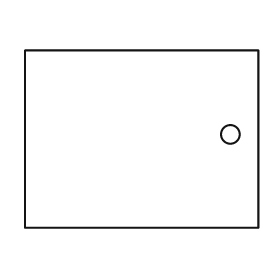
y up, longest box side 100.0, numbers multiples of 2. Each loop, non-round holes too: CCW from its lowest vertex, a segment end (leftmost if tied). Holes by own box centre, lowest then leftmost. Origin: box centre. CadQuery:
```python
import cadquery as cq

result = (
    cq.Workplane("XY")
    .moveTo(-50.0, -38.0)
    .lineTo(50.0, -38.0)
    .lineTo(50.0, 38.0)
    .lineTo(-50.0, 38.0)
    .close()
    .moveTo(38.0, 2.0)
    .circle(4.0)
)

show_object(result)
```